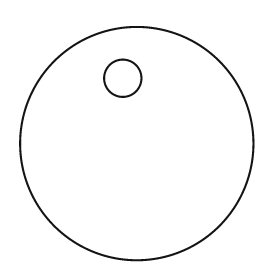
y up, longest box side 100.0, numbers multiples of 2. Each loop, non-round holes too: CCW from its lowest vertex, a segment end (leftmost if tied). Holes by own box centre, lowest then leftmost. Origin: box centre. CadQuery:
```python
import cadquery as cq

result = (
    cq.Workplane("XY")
    .moveTo(0.0, 0.0)
    .circle(50.0)
    .moveTo(-6.0, 28.0)
    .circle(8.0)
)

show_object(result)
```